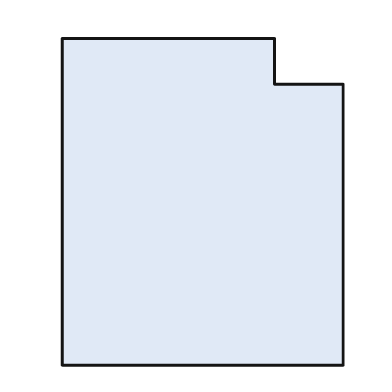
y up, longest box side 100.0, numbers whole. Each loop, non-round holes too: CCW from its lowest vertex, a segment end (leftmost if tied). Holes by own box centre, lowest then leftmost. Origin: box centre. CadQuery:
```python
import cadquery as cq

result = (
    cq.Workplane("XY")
    .moveTo(-43.0, -50.0)
    .lineTo(43.0, -50.0)
    .lineTo(43.0, 36.0)
    .lineTo(22.0, 36.0)
    .lineTo(22.0, 50.0)
    .lineTo(-43.0, 50.0)
    .close()
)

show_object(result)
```